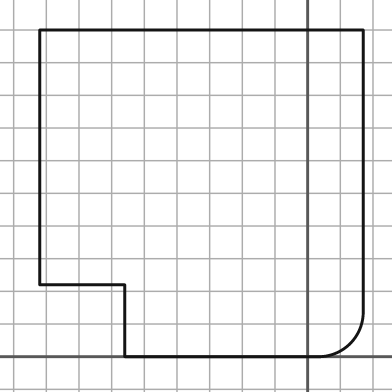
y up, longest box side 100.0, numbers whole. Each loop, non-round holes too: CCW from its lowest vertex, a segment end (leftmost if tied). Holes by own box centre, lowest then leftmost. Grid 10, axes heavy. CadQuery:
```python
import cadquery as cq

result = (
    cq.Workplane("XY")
    .moveTo(-56.0, 0.0)
    .lineTo(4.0, 0.0)
    .threePointArc((13.0, 4.0), (17.0, 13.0))
    .lineTo(17.0, 100.0)
    .lineTo(-82.0, 100.0)
    .lineTo(-82.0, 22.0)
    .lineTo(-56.0, 22.0)
    .close()
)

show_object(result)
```